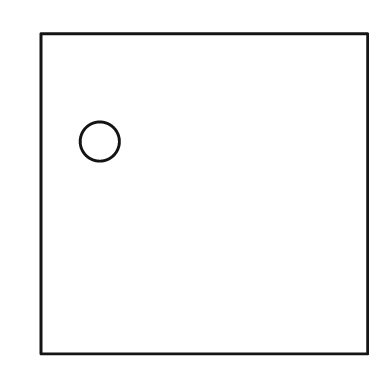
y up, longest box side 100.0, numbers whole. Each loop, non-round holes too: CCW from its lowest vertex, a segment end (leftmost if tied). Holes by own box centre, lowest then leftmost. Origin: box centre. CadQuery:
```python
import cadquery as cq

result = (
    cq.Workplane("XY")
    .moveTo(-50.0, -49.0)
    .lineTo(50.0, -49.0)
    .lineTo(50.0, 49.0)
    .lineTo(-50.0, 49.0)
    .close()
    .moveTo(-32.0, 16.0)
    .circle(6.0)
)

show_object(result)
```